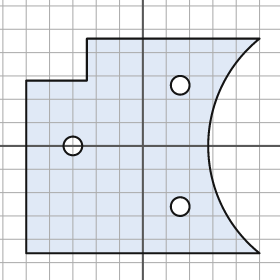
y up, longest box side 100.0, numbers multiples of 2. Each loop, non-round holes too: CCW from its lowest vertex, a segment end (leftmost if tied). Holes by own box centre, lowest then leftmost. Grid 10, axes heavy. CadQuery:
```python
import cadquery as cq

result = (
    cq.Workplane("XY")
    .moveTo(-50.0, -46.0)
    .lineTo(50.0, -46.0)
    .threePointArc((28.0, 0.0), (50.0, 46.0))
    .lineTo(-24.0, 46.0)
    .lineTo(-24.0, 28.0)
    .lineTo(-50.0, 28.0)
    .close()
    .moveTo(16.0, -26.0)
    .circle(4.0)
    .moveTo(-30.0, 0.0)
    .circle(4.0)
    .moveTo(16.0, 26.0)
    .circle(4.0)
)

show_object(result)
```